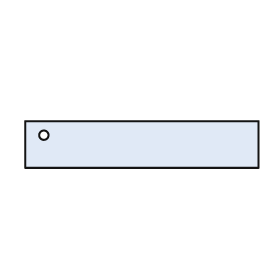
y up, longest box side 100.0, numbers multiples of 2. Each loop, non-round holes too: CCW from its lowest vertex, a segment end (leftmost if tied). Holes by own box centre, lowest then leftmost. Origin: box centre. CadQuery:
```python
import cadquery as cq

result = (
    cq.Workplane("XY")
    .moveTo(-50.0, -10.0)
    .lineTo(50.0, -10.0)
    .lineTo(50.0, 10.0)
    .lineTo(-50.0, 10.0)
    .close()
    .moveTo(-42.0, 4.0)
    .circle(2.0)
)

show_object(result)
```